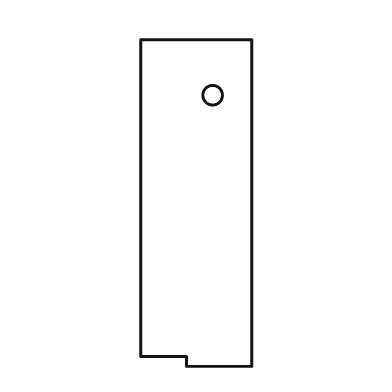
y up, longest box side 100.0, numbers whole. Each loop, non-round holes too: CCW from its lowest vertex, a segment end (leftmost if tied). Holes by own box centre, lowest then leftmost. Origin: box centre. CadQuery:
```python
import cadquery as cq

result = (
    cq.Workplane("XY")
    .moveTo(-3.0, -50.0)
    .lineTo(17.0, -50.0)
    .lineTo(17.0, 50.0)
    .lineTo(-17.0, 50.0)
    .lineTo(-17.0, -47.0)
    .lineTo(-3.0, -47.0)
    .close()
    .moveTo(5.0, 33.0)
    .circle(3.0)
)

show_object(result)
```